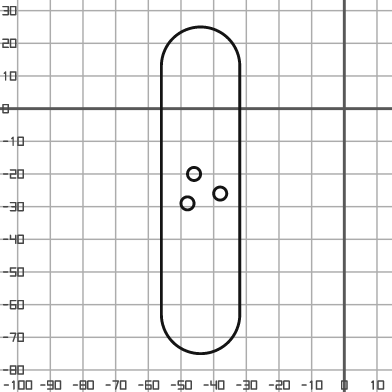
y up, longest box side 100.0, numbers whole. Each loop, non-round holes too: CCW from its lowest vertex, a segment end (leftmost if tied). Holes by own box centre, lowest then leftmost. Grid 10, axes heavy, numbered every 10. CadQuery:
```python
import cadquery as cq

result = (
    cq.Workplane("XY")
    .moveTo(-56.0, -63.0)
    .threePointArc((-44.0, -75.0), (-32.0, -63.0))
    .lineTo(-32.0, 13.0)
    .threePointArc((-44.0, 25.0), (-56.0, 13.0))
    .close()
    .moveTo(-48.0, -29.0)
    .circle(2.0)
    .moveTo(-38.0, -26.0)
    .circle(2.0)
    .moveTo(-46.0, -20.0)
    .circle(2.0)
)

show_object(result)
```